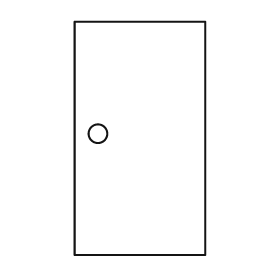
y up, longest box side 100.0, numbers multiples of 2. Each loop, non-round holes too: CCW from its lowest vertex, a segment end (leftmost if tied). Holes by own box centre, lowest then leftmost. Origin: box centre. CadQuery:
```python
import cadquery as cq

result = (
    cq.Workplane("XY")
    .moveTo(-28.0, -50.0)
    .lineTo(28.0, -50.0)
    .lineTo(28.0, 50.0)
    .lineTo(-28.0, 50.0)
    .close()
    .moveTo(-18.0, 2.0)
    .circle(4.0)
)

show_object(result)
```